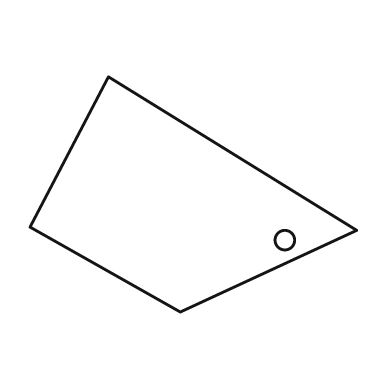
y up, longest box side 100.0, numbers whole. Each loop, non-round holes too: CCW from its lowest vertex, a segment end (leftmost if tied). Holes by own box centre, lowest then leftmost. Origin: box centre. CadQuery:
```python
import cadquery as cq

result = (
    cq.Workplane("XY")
    .moveTo(-4.0, -36.0)
    .lineTo(50.0, -11.0)
    .lineTo(-26.0, 36.0)
    .lineTo(-50.0, -10.0)
    .close()
    .moveTo(28.0, -14.0)
    .circle(3.0)
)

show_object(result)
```